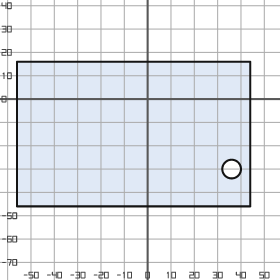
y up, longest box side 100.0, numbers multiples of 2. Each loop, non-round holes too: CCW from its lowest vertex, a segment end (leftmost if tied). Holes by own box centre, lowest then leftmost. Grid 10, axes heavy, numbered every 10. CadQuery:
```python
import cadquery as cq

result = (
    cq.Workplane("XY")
    .moveTo(-56.0, -46.0)
    .lineTo(44.0, -46.0)
    .lineTo(44.0, 16.0)
    .lineTo(-56.0, 16.0)
    .close()
    .moveTo(36.0, -30.0)
    .circle(4.0)
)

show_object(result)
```